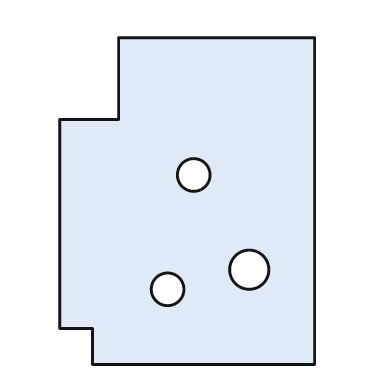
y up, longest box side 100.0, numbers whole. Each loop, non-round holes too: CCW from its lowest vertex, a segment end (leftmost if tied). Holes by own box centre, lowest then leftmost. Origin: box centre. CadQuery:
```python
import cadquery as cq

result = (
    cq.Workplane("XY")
    .moveTo(-29.0, -50.0)
    .lineTo(39.0, -50.0)
    .lineTo(39.0, 50.0)
    .lineTo(-21.0, 50.0)
    .lineTo(-21.0, 25.0)
    .lineTo(-39.0, 25.0)
    .lineTo(-39.0, -39.0)
    .lineTo(-29.0, -39.0)
    .close()
    .moveTo(-6.0, -27.0)
    .circle(5.0)
    .moveTo(19.0, -21.0)
    .circle(6.0)
    .moveTo(2.0, 8.0)
    .circle(5.0)
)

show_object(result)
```